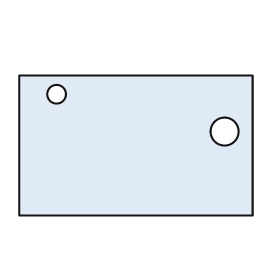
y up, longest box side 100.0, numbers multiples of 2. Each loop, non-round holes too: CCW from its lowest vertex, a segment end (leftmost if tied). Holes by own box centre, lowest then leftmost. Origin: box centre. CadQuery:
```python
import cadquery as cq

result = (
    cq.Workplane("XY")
    .moveTo(-50.0, -30.0)
    .lineTo(50.0, -30.0)
    .lineTo(50.0, 30.0)
    .lineTo(-50.0, 30.0)
    .close()
    .moveTo(38.0, 6.0)
    .circle(6.0)
    .moveTo(-34.0, 22.0)
    .circle(4.0)
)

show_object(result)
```